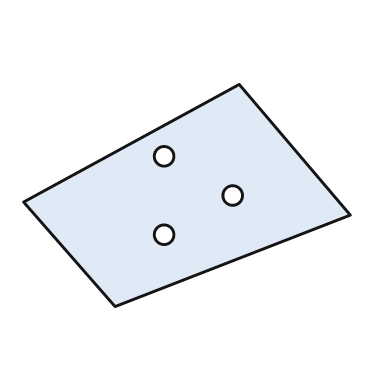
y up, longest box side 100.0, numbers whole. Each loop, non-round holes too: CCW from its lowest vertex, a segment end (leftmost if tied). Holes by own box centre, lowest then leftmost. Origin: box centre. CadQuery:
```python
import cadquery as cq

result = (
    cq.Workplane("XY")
    .moveTo(-22.0, -34.0)
    .lineTo(50.0, -6.0)
    .lineTo(16.0, 34.0)
    .lineTo(-50.0, -2.0)
    .close()
    .moveTo(-7.0, -12.0)
    .circle(3.0)
    .moveTo(14.0, 0.0)
    .circle(3.0)
    .moveTo(-7.0, 12.0)
    .circle(3.0)
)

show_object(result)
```